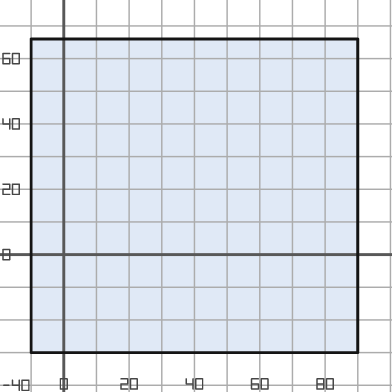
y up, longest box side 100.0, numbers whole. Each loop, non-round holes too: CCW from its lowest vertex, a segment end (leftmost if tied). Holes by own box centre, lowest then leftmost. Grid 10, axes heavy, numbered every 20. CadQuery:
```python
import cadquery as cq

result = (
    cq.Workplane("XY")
    .moveTo(-10.0, -30.0)
    .lineTo(90.0, -30.0)
    .lineTo(90.0, 66.0)
    .lineTo(-10.0, 66.0)
    .close()
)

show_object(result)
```